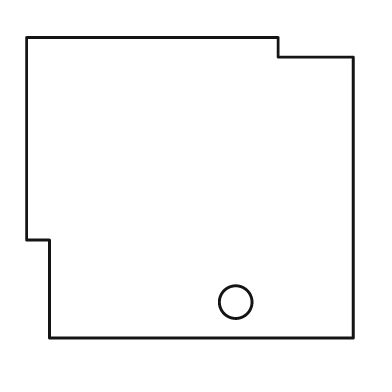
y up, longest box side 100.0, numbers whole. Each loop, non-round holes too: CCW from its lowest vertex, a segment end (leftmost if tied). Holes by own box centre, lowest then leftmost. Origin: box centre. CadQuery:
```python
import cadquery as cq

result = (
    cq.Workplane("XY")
    .moveTo(-43.0, -46.0)
    .lineTo(50.0, -46.0)
    .lineTo(50.0, 40.0)
    .lineTo(27.0, 40.0)
    .lineTo(27.0, 46.0)
    .lineTo(-50.0, 46.0)
    .lineTo(-50.0, -16.0)
    .lineTo(-43.0, -16.0)
    .close()
    .moveTo(14.0, -35.0)
    .circle(5.0)
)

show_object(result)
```